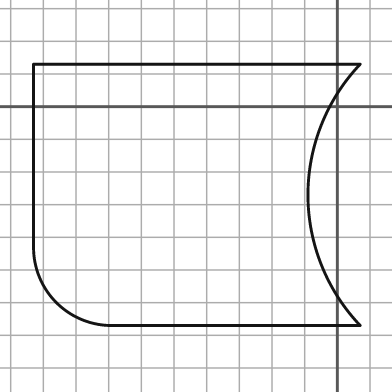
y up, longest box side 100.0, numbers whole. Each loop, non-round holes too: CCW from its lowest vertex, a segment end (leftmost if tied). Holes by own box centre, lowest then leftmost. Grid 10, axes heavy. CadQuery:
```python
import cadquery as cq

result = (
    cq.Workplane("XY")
    .moveTo(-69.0, -67.0)
    .lineTo(7.0, -67.0)
    .threePointArc((-9.0, -27.0), (7.0, 13.0))
    .lineTo(-93.0, 13.0)
    .lineTo(-93.0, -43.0)
    .threePointArc((-86.0, -60.0), (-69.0, -67.0))
    .close()
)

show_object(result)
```